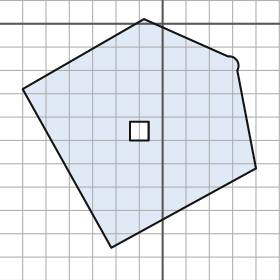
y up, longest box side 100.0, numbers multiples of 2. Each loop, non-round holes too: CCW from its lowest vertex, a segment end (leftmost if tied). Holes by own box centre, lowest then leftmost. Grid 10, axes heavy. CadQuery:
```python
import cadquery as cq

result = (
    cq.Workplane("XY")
    .moveTo(-22.0, -96.0)
    .lineTo(40.0, -62.0)
    .lineTo(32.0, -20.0)
    .threePointArc((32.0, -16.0), (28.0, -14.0))
    .lineTo(-8.0, 2.0)
    .lineTo(-60.0, -28.0)
    .close()
    .moveTo(-14.0, -50.0)
    .lineTo(-6.0, -50.0)
    .lineTo(-6.0, -42.0)
    .lineTo(-14.0, -42.0)
    .close()
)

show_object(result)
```